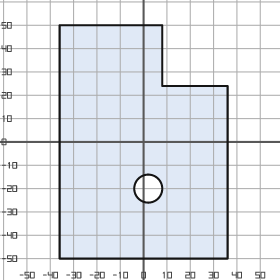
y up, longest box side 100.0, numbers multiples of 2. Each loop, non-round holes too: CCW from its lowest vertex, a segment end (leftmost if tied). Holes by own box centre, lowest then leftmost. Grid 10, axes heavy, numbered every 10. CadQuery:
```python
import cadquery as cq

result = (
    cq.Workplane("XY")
    .moveTo(-36.0, -50.0)
    .lineTo(36.0, -50.0)
    .lineTo(36.0, 24.0)
    .lineTo(8.0, 24.0)
    .lineTo(8.0, 50.0)
    .lineTo(-36.0, 50.0)
    .close()
    .moveTo(2.0, -20.0)
    .circle(6.0)
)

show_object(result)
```